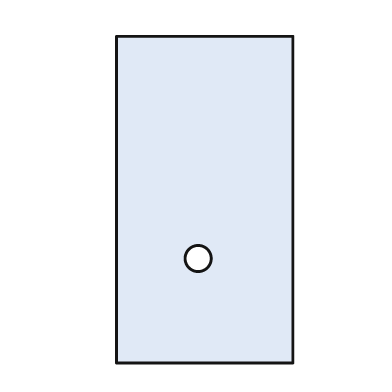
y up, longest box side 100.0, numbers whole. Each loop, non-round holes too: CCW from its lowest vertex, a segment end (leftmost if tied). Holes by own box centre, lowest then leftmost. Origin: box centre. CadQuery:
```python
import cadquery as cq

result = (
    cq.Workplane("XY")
    .moveTo(-27.0, -50.0)
    .lineTo(27.0, -50.0)
    .lineTo(27.0, 50.0)
    .lineTo(-27.0, 50.0)
    .close()
    .moveTo(-2.0, -18.0)
    .circle(4.0)
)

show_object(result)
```